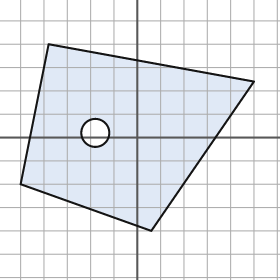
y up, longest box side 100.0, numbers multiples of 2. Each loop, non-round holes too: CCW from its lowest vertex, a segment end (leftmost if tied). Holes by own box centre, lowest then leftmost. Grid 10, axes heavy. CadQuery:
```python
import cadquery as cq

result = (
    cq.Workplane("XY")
    .moveTo(6.0, -40.0)
    .lineTo(50.0, 24.0)
    .lineTo(-38.0, 40.0)
    .lineTo(-50.0, -20.0)
    .close()
    .moveTo(-18.0, 2.0)
    .circle(6.0)
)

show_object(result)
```